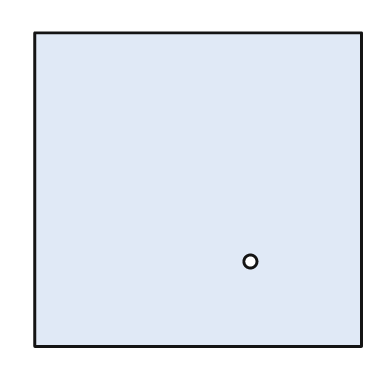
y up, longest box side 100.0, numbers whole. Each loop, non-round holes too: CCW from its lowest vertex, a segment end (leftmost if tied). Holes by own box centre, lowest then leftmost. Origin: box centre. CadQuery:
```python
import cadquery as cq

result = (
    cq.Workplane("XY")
    .moveTo(-50.0, -48.0)
    .lineTo(50.0, -48.0)
    .lineTo(50.0, 48.0)
    .lineTo(-50.0, 48.0)
    .close()
    .moveTo(16.0, -22.0)
    .circle(2.0)
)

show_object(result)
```